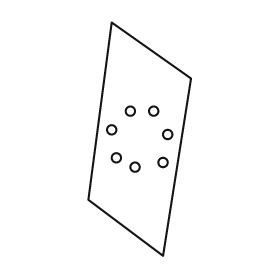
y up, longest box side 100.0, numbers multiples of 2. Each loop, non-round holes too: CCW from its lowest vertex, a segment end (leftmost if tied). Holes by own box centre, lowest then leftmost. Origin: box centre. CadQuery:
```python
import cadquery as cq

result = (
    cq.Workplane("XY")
    .moveTo(10.0, -50.0)
    .lineTo(22.0, 26.0)
    .lineTo(-12.0, 50.0)
    .lineTo(-22.0, -26.0)
    .close()
    .moveTo(-2.0, -12.0)
    .circle(2.0)
    .moveTo(10.0, -10.0)
    .circle(2.0)
    .moveTo(-10.0, -8.0)
    .circle(2.0)
    .moveTo(12.0, 2.0)
    .circle(2.0)
    .moveTo(-12.0, 4.0)
    .circle(2.0)
    .moveTo(-4.0, 12.0)
    .circle(2.0)
    .moveTo(6.0, 12.0)
    .circle(2.0)
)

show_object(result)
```